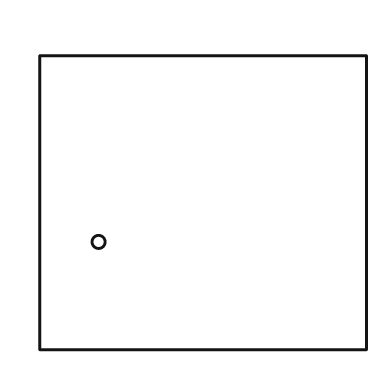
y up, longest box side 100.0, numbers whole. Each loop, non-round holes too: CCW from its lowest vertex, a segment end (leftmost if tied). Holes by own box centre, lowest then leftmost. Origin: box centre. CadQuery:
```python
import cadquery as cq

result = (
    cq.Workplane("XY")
    .moveTo(-50.0, -45.0)
    .lineTo(50.0, -45.0)
    .lineTo(50.0, 45.0)
    .lineTo(-50.0, 45.0)
    .close()
    .moveTo(-32.0, -12.0)
    .circle(2.0)
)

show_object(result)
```